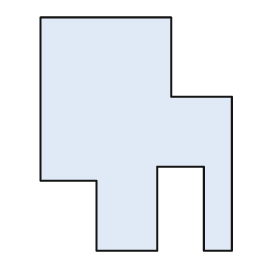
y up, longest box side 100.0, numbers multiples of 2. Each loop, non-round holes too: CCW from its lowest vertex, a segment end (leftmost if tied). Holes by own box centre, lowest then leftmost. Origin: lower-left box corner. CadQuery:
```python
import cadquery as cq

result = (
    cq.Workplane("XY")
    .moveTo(24.0, 0.0)
    .lineTo(50.0, 0.0)
    .lineTo(50.0, 36.0)
    .lineTo(70.0, 36.0)
    .lineTo(70.0, 0.0)
    .lineTo(82.0, 0.0)
    .lineTo(82.0, 66.0)
    .lineTo(56.0, 66.0)
    .lineTo(56.0, 100.0)
    .lineTo(0.0, 100.0)
    .lineTo(0.0, 30.0)
    .lineTo(24.0, 30.0)
    .close()
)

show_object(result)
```